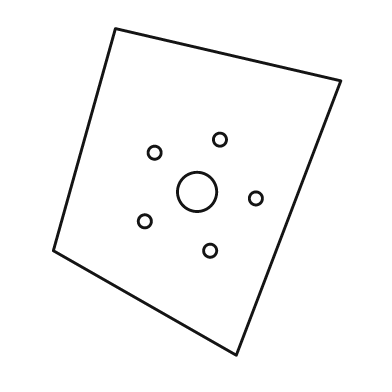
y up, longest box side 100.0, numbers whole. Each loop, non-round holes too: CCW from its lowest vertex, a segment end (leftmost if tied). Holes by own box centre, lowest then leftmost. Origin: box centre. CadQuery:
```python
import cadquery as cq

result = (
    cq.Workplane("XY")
    .moveTo(12.0, -50.0)
    .lineTo(44.0, 34.0)
    .lineTo(-25.0, 50.0)
    .lineTo(-44.0, -18.0)
    .close()
    .moveTo(4.0, -18.0)
    .circle(2.0)
    .moveTo(-16.0, -9.0)
    .circle(2.0)
    .moveTo(18.0, -2.0)
    .circle(2.0)
    .moveTo(0.0, 0.0)
    .circle(6.0)
    .moveTo(-13.0, 12.0)
    .circle(2.0)
    .moveTo(7.0, 16.0)
    .circle(2.0)
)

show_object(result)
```